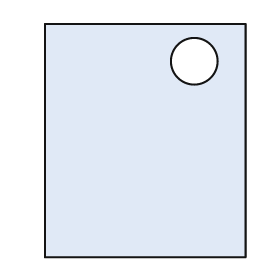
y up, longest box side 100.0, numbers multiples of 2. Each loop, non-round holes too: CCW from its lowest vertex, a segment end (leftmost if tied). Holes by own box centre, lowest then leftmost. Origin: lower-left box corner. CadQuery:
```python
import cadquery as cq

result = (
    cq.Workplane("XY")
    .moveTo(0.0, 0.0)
    .lineTo(86.0, 0.0)
    .lineTo(86.0, 100.0)
    .lineTo(0.0, 100.0)
    .close()
    .moveTo(64.0, 84.0)
    .circle(10.0)
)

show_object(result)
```